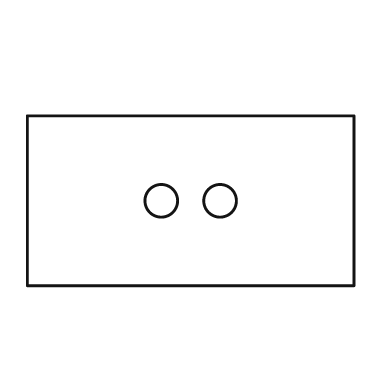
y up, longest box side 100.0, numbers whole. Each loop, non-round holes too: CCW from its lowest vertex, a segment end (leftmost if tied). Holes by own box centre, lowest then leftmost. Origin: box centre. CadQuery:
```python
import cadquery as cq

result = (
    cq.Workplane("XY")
    .moveTo(-50.0, -26.0)
    .lineTo(50.0, -26.0)
    .lineTo(50.0, 26.0)
    .lineTo(-50.0, 26.0)
    .close()
    .moveTo(-9.0, 0.0)
    .circle(5.0)
    .moveTo(9.0, 0.0)
    .circle(5.0)
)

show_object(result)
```